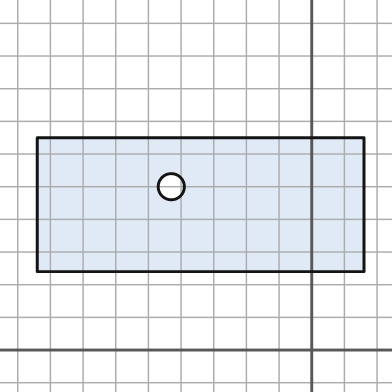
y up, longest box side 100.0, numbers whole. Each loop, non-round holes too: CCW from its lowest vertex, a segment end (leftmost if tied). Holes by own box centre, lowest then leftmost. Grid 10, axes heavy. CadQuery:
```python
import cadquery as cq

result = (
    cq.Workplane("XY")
    .moveTo(-84.0, 24.0)
    .lineTo(16.0, 24.0)
    .lineTo(16.0, 65.0)
    .lineTo(-84.0, 65.0)
    .close()
    .moveTo(-43.0, 50.0)
    .circle(4.0)
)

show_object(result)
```